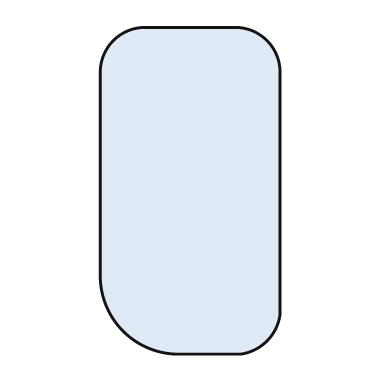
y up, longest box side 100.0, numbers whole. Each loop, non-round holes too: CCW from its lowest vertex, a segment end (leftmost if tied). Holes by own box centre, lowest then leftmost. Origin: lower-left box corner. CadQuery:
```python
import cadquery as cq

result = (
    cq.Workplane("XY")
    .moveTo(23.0, 0.0)
    .lineTo(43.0, 0.0)
    .threePointArc((51.0, 4.0), (55.0, 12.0))
    .lineTo(55.0, 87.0)
    .threePointArc((51.0, 96.0), (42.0, 100.0))
    .lineTo(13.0, 100.0)
    .threePointArc((4.0, 96.0), (0.0, 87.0))
    .lineTo(0.0, 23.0)
    .threePointArc((7.0, 7.0), (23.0, 0.0))
    .close()
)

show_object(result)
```